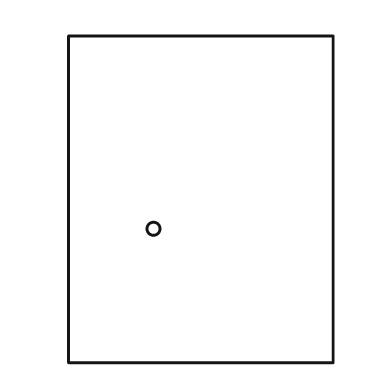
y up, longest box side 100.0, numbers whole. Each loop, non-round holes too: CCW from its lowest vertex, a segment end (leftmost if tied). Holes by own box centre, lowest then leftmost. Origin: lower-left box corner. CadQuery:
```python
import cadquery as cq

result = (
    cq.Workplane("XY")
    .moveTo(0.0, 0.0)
    .lineTo(81.0, 0.0)
    .lineTo(81.0, 100.0)
    .lineTo(0.0, 100.0)
    .close()
    .moveTo(26.0, 41.0)
    .circle(2.0)
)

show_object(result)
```